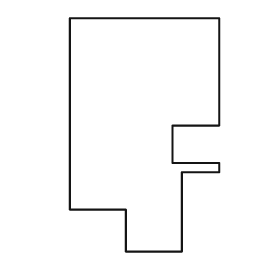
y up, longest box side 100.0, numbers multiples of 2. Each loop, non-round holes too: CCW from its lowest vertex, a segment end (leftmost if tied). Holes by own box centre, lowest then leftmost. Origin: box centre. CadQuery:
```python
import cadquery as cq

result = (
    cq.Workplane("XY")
    .moveTo(-8.0, -50.0)
    .lineTo(16.0, -50.0)
    .lineTo(16.0, -16.0)
    .lineTo(32.0, -16.0)
    .lineTo(32.0, -12.0)
    .lineTo(12.0, -12.0)
    .lineTo(12.0, 4.0)
    .lineTo(32.0, 4.0)
    .lineTo(32.0, 50.0)
    .lineTo(-32.0, 50.0)
    .lineTo(-32.0, -32.0)
    .lineTo(-8.0, -32.0)
    .close()
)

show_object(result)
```